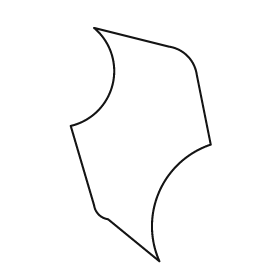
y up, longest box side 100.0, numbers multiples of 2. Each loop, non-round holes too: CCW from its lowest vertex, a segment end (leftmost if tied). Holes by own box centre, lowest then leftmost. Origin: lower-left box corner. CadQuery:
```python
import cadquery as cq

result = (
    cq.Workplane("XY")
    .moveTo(38.0, 0.0)
    .threePointArc((38.0, 30.0), (60.0, 50.0))
    .lineTo(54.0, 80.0)
    .threePointArc((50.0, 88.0), (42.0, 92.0))
    .lineTo(10.0, 100.0)
    .threePointArc((18.0, 76.0), (0.0, 58.0))
    .lineTo(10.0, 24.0)
    .threePointArc((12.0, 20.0), (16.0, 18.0))
    .close()
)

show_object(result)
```